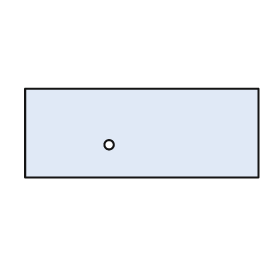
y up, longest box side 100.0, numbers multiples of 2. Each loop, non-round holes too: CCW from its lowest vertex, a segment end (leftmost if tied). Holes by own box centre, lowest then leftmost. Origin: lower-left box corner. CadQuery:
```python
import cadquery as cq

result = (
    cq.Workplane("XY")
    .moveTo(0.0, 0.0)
    .lineTo(100.0, 0.0)
    .lineTo(100.0, 38.0)
    .lineTo(0.0, 38.0)
    .close()
    .moveTo(36.0, 14.0)
    .circle(2.0)
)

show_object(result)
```